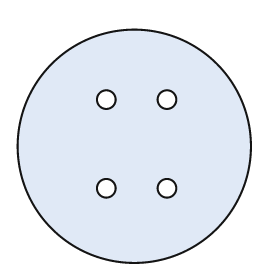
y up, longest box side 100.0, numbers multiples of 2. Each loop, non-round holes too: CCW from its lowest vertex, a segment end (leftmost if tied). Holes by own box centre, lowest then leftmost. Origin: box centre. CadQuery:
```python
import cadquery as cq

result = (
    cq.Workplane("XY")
    .moveTo(0.0, 0.0)
    .circle(50.0)
    .moveTo(-12.0, -18.0)
    .circle(4.0)
    .moveTo(14.0, -18.0)
    .circle(4.0)
    .moveTo(-12.0, 20.0)
    .circle(4.0)
    .moveTo(14.0, 20.0)
    .circle(4.0)
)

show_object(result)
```